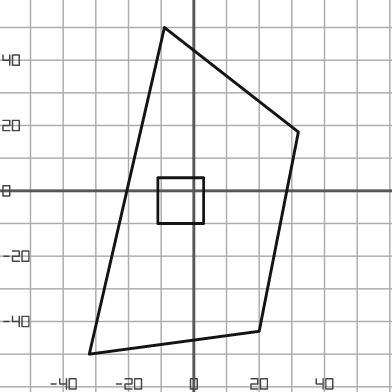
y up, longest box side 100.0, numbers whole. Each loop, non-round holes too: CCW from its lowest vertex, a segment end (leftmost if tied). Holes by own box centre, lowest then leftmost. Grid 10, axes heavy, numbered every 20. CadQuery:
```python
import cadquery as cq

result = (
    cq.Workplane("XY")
    .moveTo(-32.0, -50.0)
    .lineTo(20.0, -43.0)
    .lineTo(32.0, 18.0)
    .lineTo(-9.0, 50.0)
    .close()
    .moveTo(-11.0, -10.0)
    .lineTo(3.0, -10.0)
    .lineTo(3.0, 4.0)
    .lineTo(-11.0, 4.0)
    .close()
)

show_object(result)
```